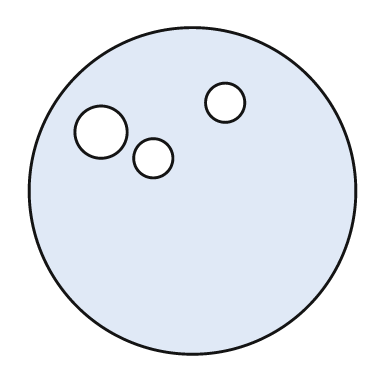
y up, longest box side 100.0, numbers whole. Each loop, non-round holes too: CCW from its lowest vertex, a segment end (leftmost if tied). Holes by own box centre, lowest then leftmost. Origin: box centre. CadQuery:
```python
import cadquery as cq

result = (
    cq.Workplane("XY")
    .moveTo(0.0, 0.0)
    .circle(50.0)
    .moveTo(-12.0, 10.0)
    .circle(6.0)
    .moveTo(-28.0, 18.0)
    .circle(8.0)
    .moveTo(10.0, 27.0)
    .circle(6.0)
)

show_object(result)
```